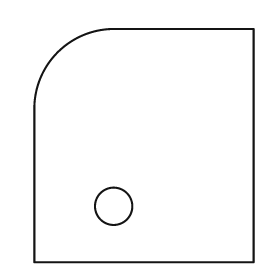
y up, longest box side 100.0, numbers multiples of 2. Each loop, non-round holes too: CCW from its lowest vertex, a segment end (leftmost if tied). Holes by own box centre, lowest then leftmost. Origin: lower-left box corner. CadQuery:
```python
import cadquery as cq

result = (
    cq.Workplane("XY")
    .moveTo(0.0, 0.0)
    .lineTo(94.0, 0.0)
    .lineTo(94.0, 100.0)
    .lineTo(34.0, 100.0)
    .threePointArc((10.0, 90.0), (0.0, 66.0))
    .close()
    .moveTo(34.0, 24.0)
    .circle(8.0)
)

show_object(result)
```